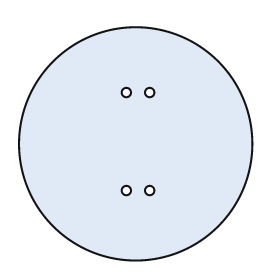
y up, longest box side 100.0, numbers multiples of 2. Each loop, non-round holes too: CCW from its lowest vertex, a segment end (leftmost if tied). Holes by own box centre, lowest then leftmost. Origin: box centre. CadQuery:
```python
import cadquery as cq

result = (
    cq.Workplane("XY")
    .moveTo(0.0, 0.0)
    .circle(50.0)
    .moveTo(-4.0, -20.0)
    .circle(2.0)
    .moveTo(6.0, -20.0)
    .circle(2.0)
    .moveTo(-4.0, 22.0)
    .circle(2.0)
    .moveTo(6.0, 22.0)
    .circle(2.0)
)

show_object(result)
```